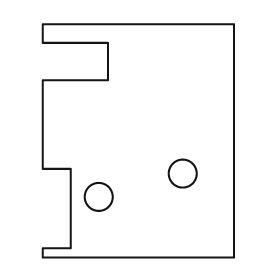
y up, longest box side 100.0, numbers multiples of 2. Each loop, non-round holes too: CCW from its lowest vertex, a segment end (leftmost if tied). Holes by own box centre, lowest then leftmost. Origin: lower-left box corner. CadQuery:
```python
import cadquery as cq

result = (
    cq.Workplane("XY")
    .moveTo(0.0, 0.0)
    .lineTo(82.0, 0.0)
    .lineTo(82.0, 100.0)
    .lineTo(0.0, 100.0)
    .lineTo(0.0, 92.0)
    .lineTo(28.0, 92.0)
    .lineTo(28.0, 76.0)
    .lineTo(0.0, 76.0)
    .lineTo(0.0, 38.0)
    .lineTo(12.0, 38.0)
    .lineTo(12.0, 4.0)
    .lineTo(0.0, 4.0)
    .close()
    .moveTo(24.0, 26.0)
    .circle(6.0)
    .moveTo(60.0, 36.0)
    .circle(6.0)
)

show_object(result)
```